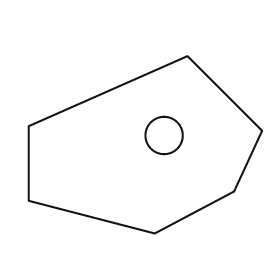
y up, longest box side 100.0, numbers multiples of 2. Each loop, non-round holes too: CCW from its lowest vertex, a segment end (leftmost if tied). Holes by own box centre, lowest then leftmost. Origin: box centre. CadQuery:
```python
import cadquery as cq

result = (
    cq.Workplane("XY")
    .moveTo(4.0, -38.0)
    .lineTo(38.0, -20.0)
    .lineTo(50.0, 6.0)
    .lineTo(18.0, 38.0)
    .lineTo(-50.0, 8.0)
    .lineTo(-50.0, -24.0)
    .close()
    .moveTo(8.0, 4.0)
    .circle(8.0)
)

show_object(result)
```